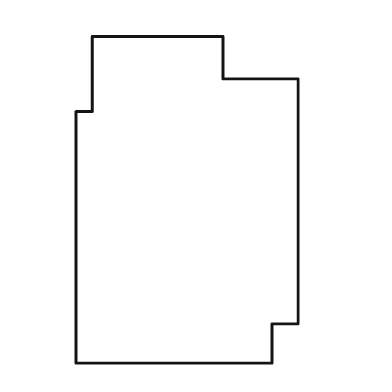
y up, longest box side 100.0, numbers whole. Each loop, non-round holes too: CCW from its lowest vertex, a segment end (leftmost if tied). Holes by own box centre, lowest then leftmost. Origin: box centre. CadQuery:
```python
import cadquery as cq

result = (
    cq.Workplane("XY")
    .moveTo(-34.0, -50.0)
    .lineTo(26.0, -50.0)
    .lineTo(26.0, -38.0)
    .lineTo(34.0, -38.0)
    .lineTo(34.0, 37.0)
    .lineTo(11.0, 37.0)
    .lineTo(11.0, 50.0)
    .lineTo(-29.0, 50.0)
    .lineTo(-29.0, 27.0)
    .lineTo(-34.0, 27.0)
    .close()
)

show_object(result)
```